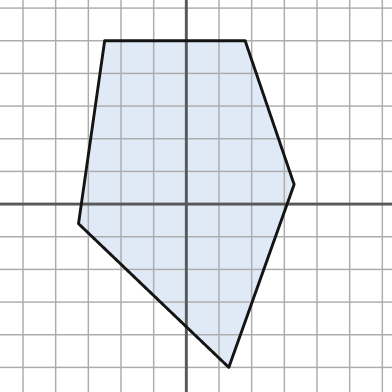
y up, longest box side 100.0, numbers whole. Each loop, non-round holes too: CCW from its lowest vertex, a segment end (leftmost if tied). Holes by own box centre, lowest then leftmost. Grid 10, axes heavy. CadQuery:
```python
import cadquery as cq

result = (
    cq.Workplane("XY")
    .moveTo(13.0, -50.0)
    .lineTo(33.0, 6.0)
    .lineTo(18.0, 50.0)
    .lineTo(-25.0, 50.0)
    .lineTo(-33.0, -6.0)
    .close()
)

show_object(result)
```